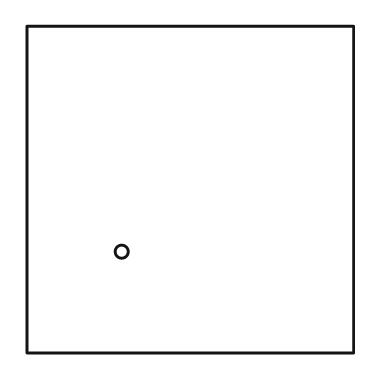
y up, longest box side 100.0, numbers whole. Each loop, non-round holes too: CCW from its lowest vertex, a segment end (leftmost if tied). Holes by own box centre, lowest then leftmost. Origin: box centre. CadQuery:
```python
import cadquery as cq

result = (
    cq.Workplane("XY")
    .moveTo(-50.0, -50.0)
    .lineTo(50.0, -50.0)
    .lineTo(50.0, 50.0)
    .lineTo(-50.0, 50.0)
    .close()
    .moveTo(-21.0, -19.0)
    .circle(2.0)
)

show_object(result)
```